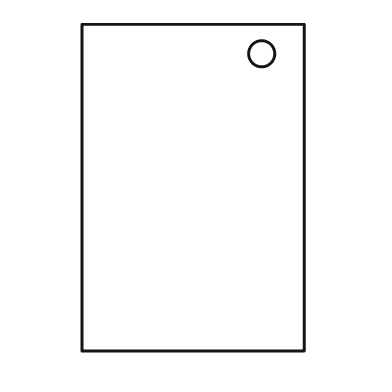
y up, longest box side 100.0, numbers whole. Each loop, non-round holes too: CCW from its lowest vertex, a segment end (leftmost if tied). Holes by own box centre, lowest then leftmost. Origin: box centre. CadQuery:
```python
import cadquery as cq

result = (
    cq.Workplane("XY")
    .moveTo(-34.0, -50.0)
    .lineTo(34.0, -50.0)
    .lineTo(34.0, 50.0)
    .lineTo(-34.0, 50.0)
    .close()
    .moveTo(21.0, 41.0)
    .circle(4.0)
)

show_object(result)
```